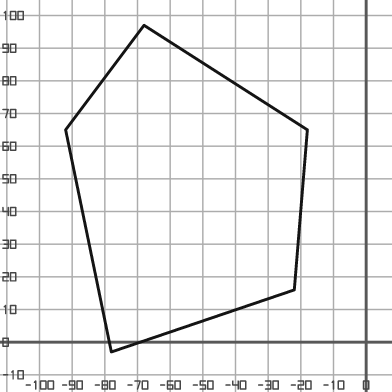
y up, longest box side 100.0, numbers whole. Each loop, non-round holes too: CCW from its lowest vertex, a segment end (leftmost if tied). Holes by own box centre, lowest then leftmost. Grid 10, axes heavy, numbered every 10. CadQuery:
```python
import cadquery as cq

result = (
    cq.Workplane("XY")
    .moveTo(-78.0, -3.0)
    .lineTo(-22.0, 16.0)
    .lineTo(-18.0, 65.0)
    .lineTo(-68.0, 97.0)
    .lineTo(-92.0, 65.0)
    .close()
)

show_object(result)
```